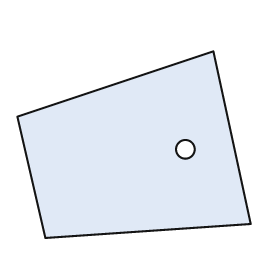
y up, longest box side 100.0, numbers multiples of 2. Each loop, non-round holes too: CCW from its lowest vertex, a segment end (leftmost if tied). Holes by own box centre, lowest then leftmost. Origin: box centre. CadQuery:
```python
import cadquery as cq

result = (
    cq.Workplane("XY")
    .moveTo(-38.0, -40.0)
    .lineTo(50.0, -34.0)
    .lineTo(34.0, 40.0)
    .lineTo(-50.0, 12.0)
    .close()
    .moveTo(22.0, -2.0)
    .circle(4.0)
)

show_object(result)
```